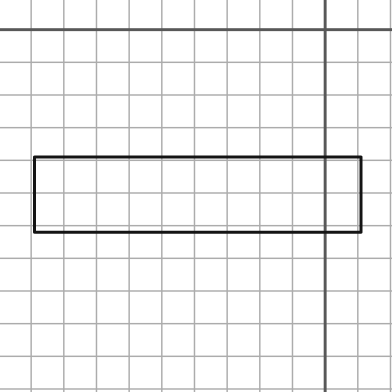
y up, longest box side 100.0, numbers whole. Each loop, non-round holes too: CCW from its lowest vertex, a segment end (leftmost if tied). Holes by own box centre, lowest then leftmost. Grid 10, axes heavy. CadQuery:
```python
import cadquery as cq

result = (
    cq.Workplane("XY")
    .moveTo(-89.0, -62.0)
    .lineTo(11.0, -62.0)
    .lineTo(11.0, -39.0)
    .lineTo(-89.0, -39.0)
    .close()
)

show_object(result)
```